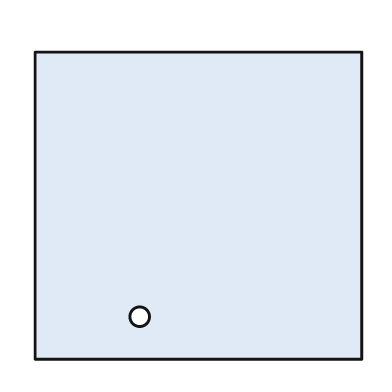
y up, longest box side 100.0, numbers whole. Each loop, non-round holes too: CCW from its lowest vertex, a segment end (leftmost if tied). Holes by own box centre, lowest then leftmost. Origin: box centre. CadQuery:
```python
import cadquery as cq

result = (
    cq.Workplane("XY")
    .moveTo(-50.0, -47.0)
    .lineTo(50.0, -47.0)
    .lineTo(50.0, 47.0)
    .lineTo(-50.0, 47.0)
    .close()
    .moveTo(-18.0, -34.0)
    .circle(3.0)
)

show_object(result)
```